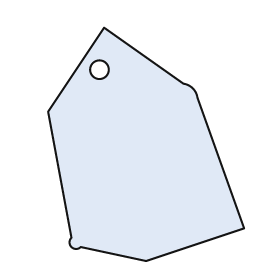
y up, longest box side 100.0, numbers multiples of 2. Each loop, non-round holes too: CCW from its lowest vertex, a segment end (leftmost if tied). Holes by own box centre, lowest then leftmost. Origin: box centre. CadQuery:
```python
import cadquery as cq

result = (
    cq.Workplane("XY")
    .moveTo(0.0, -50.0)
    .lineTo(42.0, -36.0)
    .lineTo(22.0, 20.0)
    .threePointArc((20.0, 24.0), (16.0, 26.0))
    .lineTo(-18.0, 50.0)
    .lineTo(-42.0, 14.0)
    .lineTo(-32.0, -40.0)
    .threePointArc((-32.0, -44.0), (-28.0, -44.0))
    .close()
    .moveTo(-20.0, 32.0)
    .circle(4.0)
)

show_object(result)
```